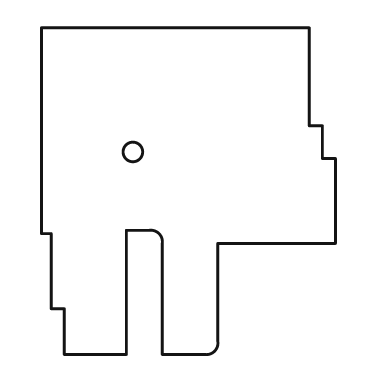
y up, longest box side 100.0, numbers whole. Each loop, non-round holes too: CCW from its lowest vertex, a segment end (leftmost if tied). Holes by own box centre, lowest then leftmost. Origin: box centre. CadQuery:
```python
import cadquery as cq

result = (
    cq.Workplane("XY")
    .moveTo(-38.0, -50.0)
    .lineTo(-19.0, -50.0)
    .lineTo(-19.0, -12.0)
    .lineTo(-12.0, -12.0)
    .threePointArc((-9.0, -13.0), (-8.0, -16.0))
    .lineTo(-8.0, -50.0)
    .lineTo(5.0, -50.0)
    .threePointArc((8.0, -49.0), (9.0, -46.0))
    .lineTo(9.0, -16.0)
    .lineTo(45.0, -16.0)
    .lineTo(45.0, 10.0)
    .lineTo(41.0, 10.0)
    .lineTo(41.0, 20.0)
    .lineTo(37.0, 20.0)
    .lineTo(37.0, 50.0)
    .lineTo(-45.0, 50.0)
    .lineTo(-45.0, -13.0)
    .lineTo(-42.0, -13.0)
    .lineTo(-42.0, -36.0)
    .lineTo(-38.0, -36.0)
    .close()
    .moveTo(-17.0, 12.0)
    .circle(3.0)
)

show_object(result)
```